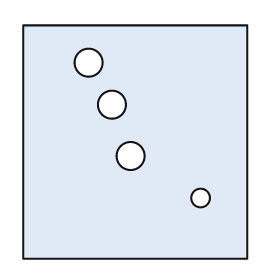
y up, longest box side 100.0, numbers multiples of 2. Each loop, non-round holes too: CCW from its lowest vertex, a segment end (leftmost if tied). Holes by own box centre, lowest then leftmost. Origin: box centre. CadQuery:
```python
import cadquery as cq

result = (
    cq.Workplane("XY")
    .moveTo(-48.0, -50.0)
    .lineTo(48.0, -50.0)
    .lineTo(48.0, 50.0)
    .lineTo(-48.0, 50.0)
    .close()
    .moveTo(28.0, -24.0)
    .circle(4.0)
    .moveTo(-2.0, -6.0)
    .circle(6.0)
    .moveTo(-10.0, 16.0)
    .circle(6.0)
    .moveTo(-20.0, 34.0)
    .circle(6.0)
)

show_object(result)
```